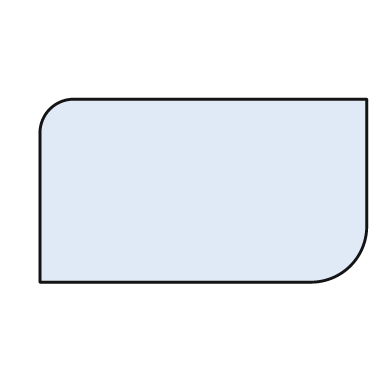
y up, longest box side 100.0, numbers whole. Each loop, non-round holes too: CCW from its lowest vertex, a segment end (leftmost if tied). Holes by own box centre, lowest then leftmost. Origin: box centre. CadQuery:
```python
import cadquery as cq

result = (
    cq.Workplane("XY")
    .moveTo(-50.0, -28.0)
    .lineTo(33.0, -28.0)
    .threePointArc((45.0, -23.0), (50.0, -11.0))
    .lineTo(50.0, 28.0)
    .lineTo(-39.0, 28.0)
    .threePointArc((-47.0, 25.0), (-50.0, 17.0))
    .close()
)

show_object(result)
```